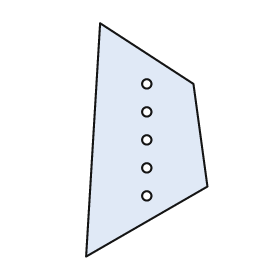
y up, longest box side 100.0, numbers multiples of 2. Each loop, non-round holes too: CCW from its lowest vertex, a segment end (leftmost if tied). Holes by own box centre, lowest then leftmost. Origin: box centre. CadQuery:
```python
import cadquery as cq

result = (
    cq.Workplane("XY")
    .moveTo(-26.0, -50.0)
    .lineTo(26.0, -20.0)
    .lineTo(20.0, 24.0)
    .lineTo(-20.0, 50.0)
    .close()
    .moveTo(0.0, -24.0)
    .circle(2.0)
    .moveTo(0.0, -12.0)
    .circle(2.0)
    .moveTo(0.0, 0.0)
    .circle(2.0)
    .moveTo(0.0, 12.0)
    .circle(2.0)
    .moveTo(0.0, 24.0)
    .circle(2.0)
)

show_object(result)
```